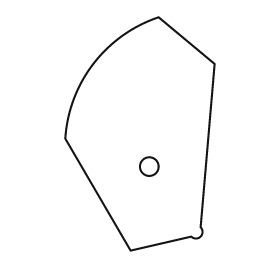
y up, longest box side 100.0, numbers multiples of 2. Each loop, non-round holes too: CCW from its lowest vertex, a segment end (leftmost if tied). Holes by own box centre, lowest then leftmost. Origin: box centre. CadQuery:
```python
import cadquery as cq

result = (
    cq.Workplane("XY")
    .moveTo(-4.0, -50.0)
    .lineTo(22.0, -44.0)
    .threePointArc((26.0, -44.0), (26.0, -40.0))
    .lineTo(32.0, 30.0)
    .lineTo(8.0, 50.0)
    .threePointArc((-20.0, 30.0), (-32.0, -2.0))
    .close()
    .moveTo(4.0, -14.0)
    .circle(4.0)
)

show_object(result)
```